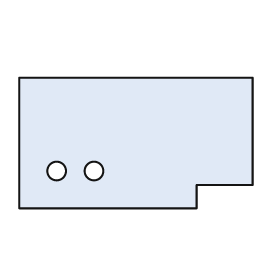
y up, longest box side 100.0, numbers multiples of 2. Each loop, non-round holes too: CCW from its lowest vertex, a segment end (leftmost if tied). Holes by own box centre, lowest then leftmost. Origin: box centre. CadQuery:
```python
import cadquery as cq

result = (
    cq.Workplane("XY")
    .moveTo(-50.0, -28.0)
    .lineTo(26.0, -28.0)
    .lineTo(26.0, -18.0)
    .lineTo(50.0, -18.0)
    .lineTo(50.0, 28.0)
    .lineTo(-50.0, 28.0)
    .close()
    .moveTo(-34.0, -12.0)
    .circle(4.0)
    .moveTo(-18.0, -12.0)
    .circle(4.0)
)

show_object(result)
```